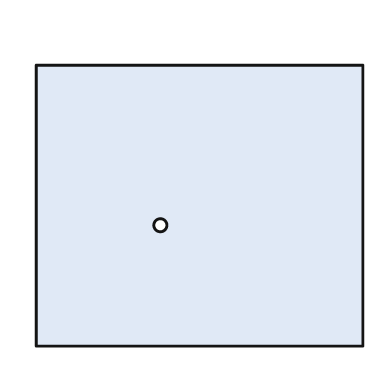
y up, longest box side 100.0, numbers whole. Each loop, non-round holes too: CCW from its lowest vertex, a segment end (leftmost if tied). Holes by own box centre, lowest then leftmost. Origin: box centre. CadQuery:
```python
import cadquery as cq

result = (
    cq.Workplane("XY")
    .moveTo(-50.0, -43.0)
    .lineTo(50.0, -43.0)
    .lineTo(50.0, 43.0)
    .lineTo(-50.0, 43.0)
    .close()
    .moveTo(-12.0, -6.0)
    .circle(2.0)
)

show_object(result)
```